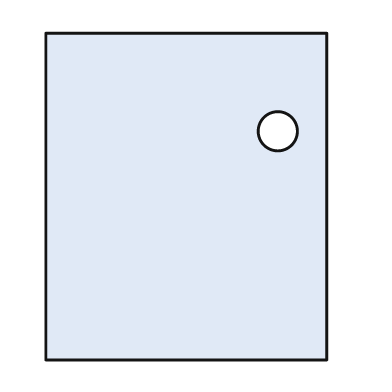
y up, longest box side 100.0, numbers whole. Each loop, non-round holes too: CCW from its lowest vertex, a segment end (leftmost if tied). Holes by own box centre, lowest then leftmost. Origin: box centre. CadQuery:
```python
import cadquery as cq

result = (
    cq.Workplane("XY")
    .moveTo(-43.0, -50.0)
    .lineTo(43.0, -50.0)
    .lineTo(43.0, 50.0)
    .lineTo(-43.0, 50.0)
    .close()
    .moveTo(28.0, 20.0)
    .circle(6.0)
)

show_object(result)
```